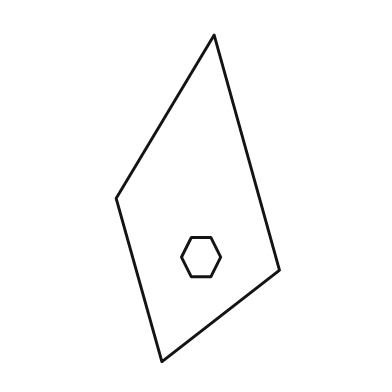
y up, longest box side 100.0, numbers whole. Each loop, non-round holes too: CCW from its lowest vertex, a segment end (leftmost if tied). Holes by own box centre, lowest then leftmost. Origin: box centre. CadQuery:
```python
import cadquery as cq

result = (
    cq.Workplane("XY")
    .moveTo(-11.0, -50.0)
    .lineTo(25.0, -22.0)
    .lineTo(5.0, 50.0)
    .lineTo(-25.0, 0.0)
    .close()
    .moveTo(-2.0, -24.0)
    .lineTo(4.0, -24.0)
    .lineTo(7.0, -18.0)
    .lineTo(4.0, -12.0)
    .lineTo(-2.0, -12.0)
    .lineTo(-5.0, -18.0)
    .close()
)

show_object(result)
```